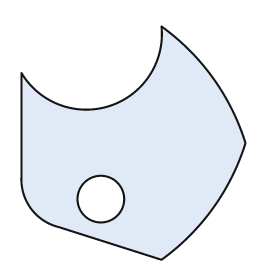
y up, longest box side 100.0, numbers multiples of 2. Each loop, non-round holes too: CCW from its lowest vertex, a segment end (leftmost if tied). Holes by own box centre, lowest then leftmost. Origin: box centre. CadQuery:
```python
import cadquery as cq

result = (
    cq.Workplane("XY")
    .moveTo(12.0, -50.0)
    .threePointArc((34.0, -28.0), (48.0, 0.0))
    .threePointArc((34.0, 28.0), (12.0, 50.0))
    .threePointArc((-10.0, 16.0), (-48.0, 30.0))
    .lineTo(-48.0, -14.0)
    .threePointArc((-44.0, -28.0), (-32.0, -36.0))
    .close()
    .moveTo(-14.0, -24.0)
    .circle(10.0)
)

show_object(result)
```